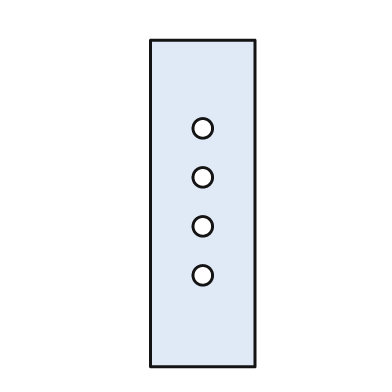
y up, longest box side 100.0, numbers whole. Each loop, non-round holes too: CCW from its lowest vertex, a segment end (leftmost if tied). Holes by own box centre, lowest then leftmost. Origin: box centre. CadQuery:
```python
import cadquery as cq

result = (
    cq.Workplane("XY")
    .moveTo(-16.0, -50.0)
    .lineTo(16.0, -50.0)
    .lineTo(16.0, 50.0)
    .lineTo(-16.0, 50.0)
    .close()
    .moveTo(0.0, -22.0)
    .circle(3.0)
    .moveTo(0.0, -7.0)
    .circle(3.0)
    .moveTo(0.0, 8.0)
    .circle(3.0)
    .moveTo(0.0, 23.0)
    .circle(3.0)
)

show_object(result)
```